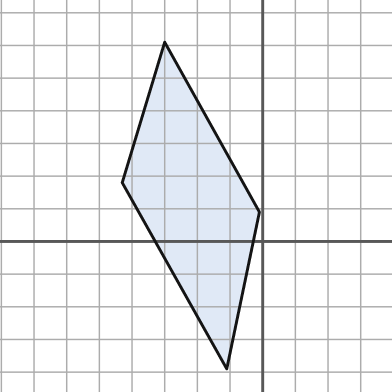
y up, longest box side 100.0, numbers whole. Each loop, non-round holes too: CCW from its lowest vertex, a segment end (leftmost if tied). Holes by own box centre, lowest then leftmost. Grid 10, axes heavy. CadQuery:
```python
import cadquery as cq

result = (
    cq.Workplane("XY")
    .moveTo(-11.0, -39.0)
    .lineTo(-1.0, 9.0)
    .lineTo(-30.0, 61.0)
    .lineTo(-43.0, 18.0)
    .close()
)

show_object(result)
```